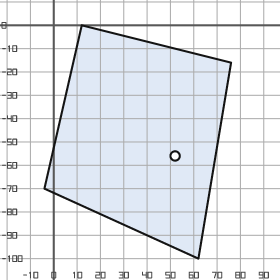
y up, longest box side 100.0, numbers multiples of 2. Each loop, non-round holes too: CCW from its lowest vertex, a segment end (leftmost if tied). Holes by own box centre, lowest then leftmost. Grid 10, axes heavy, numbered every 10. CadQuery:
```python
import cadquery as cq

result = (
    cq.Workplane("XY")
    .moveTo(62.0, -100.0)
    .lineTo(76.0, -16.0)
    .lineTo(12.0, 0.0)
    .lineTo(-4.0, -70.0)
    .close()
    .moveTo(52.0, -56.0)
    .circle(2.0)
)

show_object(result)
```